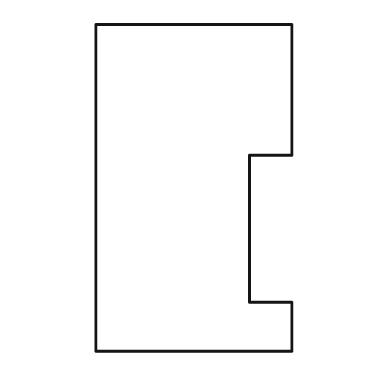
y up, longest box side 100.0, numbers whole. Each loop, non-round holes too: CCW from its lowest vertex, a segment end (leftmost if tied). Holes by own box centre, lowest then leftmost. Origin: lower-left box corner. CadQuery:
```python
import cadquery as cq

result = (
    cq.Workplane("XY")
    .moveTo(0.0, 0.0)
    .lineTo(60.0, 0.0)
    .lineTo(60.0, 15.0)
    .lineTo(47.0, 15.0)
    .lineTo(47.0, 60.0)
    .lineTo(60.0, 60.0)
    .lineTo(60.0, 100.0)
    .lineTo(0.0, 100.0)
    .close()
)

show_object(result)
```